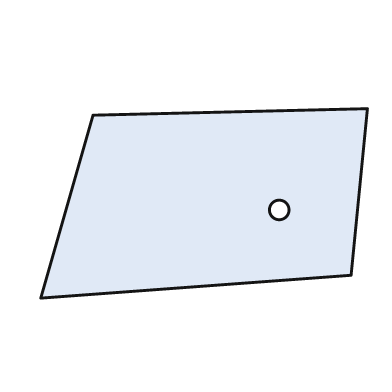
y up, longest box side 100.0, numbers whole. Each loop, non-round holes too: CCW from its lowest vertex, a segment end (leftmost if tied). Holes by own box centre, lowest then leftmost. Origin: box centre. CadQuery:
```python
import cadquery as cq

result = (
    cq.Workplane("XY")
    .moveTo(-50.0, -29.0)
    .lineTo(45.0, -22.0)
    .lineTo(50.0, 29.0)
    .lineTo(-34.0, 27.0)
    .close()
    .moveTo(23.0, -2.0)
    .circle(3.0)
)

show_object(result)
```